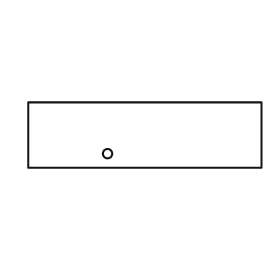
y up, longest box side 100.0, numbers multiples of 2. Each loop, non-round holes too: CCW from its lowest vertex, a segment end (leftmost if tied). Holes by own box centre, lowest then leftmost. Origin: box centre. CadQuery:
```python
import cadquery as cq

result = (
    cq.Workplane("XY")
    .moveTo(-50.0, -14.0)
    .lineTo(50.0, -14.0)
    .lineTo(50.0, 14.0)
    .lineTo(-50.0, 14.0)
    .close()
    .moveTo(-16.0, -8.0)
    .circle(2.0)
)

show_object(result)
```